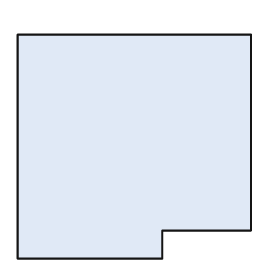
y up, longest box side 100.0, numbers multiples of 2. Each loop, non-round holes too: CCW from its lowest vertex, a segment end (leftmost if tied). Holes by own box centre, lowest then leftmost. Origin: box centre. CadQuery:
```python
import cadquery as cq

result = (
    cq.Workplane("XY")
    .moveTo(-50.0, -48.0)
    .lineTo(12.0, -48.0)
    .lineTo(12.0, -36.0)
    .lineTo(50.0, -36.0)
    .lineTo(50.0, 48.0)
    .lineTo(-50.0, 48.0)
    .close()
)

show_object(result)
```